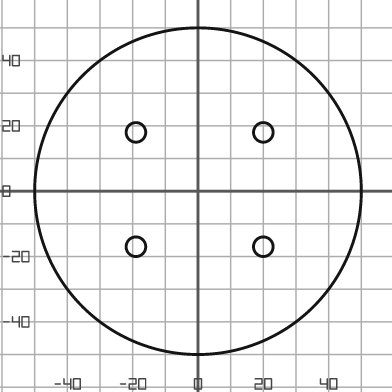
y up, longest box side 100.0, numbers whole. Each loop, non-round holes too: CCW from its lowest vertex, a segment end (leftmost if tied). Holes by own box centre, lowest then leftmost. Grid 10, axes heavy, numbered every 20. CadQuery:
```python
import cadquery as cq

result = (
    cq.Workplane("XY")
    .moveTo(0.0, 0.0)
    .circle(50.0)
    .moveTo(-19.0, -17.0)
    .circle(3.0)
    .moveTo(20.0, -17.0)
    .circle(3.0)
    .moveTo(-19.0, 18.0)
    .circle(3.0)
    .moveTo(20.0, 18.0)
    .circle(3.0)
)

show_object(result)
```